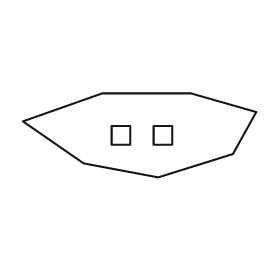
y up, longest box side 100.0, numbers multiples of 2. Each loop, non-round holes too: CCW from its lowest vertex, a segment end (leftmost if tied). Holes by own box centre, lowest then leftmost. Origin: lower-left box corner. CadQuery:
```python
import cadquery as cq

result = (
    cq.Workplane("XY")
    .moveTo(58.0, 0.0)
    .lineTo(90.0, 10.0)
    .lineTo(100.0, 28.0)
    .lineTo(72.0, 36.0)
    .lineTo(34.0, 36.0)
    .lineTo(0.0, 24.0)
    .lineTo(26.0, 6.0)
    .close()
    .moveTo(38.0, 14.0)
    .lineTo(46.0, 14.0)
    .lineTo(46.0, 22.0)
    .lineTo(38.0, 22.0)
    .close()
    .moveTo(56.0, 14.0)
    .lineTo(64.0, 14.0)
    .lineTo(64.0, 22.0)
    .lineTo(56.0, 22.0)
    .close()
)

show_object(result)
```